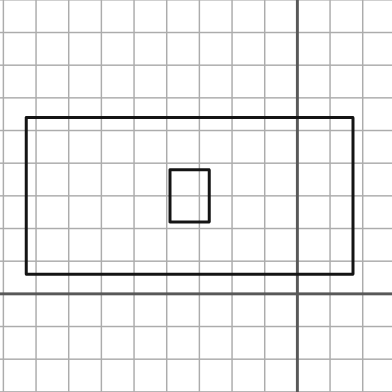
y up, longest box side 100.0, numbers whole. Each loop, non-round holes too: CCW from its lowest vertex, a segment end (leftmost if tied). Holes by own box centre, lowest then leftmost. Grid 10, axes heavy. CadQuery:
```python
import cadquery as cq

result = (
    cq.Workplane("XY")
    .moveTo(-83.0, 6.0)
    .lineTo(17.0, 6.0)
    .lineTo(17.0, 54.0)
    .lineTo(-83.0, 54.0)
    .close()
    .moveTo(-39.0, 22.0)
    .lineTo(-27.0, 22.0)
    .lineTo(-27.0, 38.0)
    .lineTo(-39.0, 38.0)
    .close()
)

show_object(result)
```